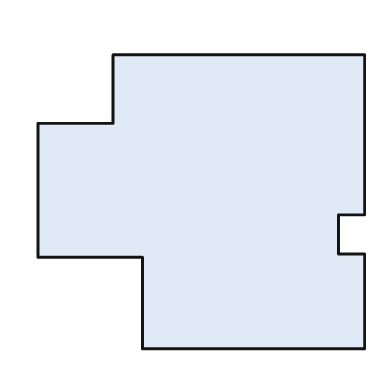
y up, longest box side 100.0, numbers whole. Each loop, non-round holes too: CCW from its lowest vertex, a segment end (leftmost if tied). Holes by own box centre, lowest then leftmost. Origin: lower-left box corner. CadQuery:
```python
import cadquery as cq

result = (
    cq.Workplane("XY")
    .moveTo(32.0, 0.0)
    .lineTo(100.0, 0.0)
    .lineTo(100.0, 29.0)
    .lineTo(92.0, 29.0)
    .lineTo(92.0, 41.0)
    .lineTo(100.0, 41.0)
    .lineTo(100.0, 90.0)
    .lineTo(23.0, 90.0)
    .lineTo(23.0, 69.0)
    .lineTo(0.0, 69.0)
    .lineTo(0.0, 28.0)
    .lineTo(32.0, 28.0)
    .close()
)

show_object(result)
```